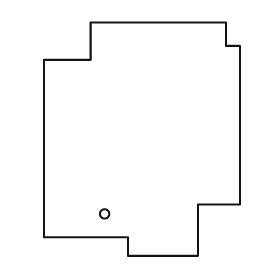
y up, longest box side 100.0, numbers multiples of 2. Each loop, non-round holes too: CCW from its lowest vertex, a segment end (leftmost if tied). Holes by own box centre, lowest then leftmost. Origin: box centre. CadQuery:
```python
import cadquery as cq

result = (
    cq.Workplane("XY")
    .moveTo(-6.0, -50.0)
    .lineTo(24.0, -50.0)
    .lineTo(24.0, -28.0)
    .lineTo(42.0, -28.0)
    .lineTo(42.0, 40.0)
    .lineTo(36.0, 40.0)
    .lineTo(36.0, 50.0)
    .lineTo(-22.0, 50.0)
    .lineTo(-22.0, 34.0)
    .lineTo(-42.0, 34.0)
    .lineTo(-42.0, -42.0)
    .lineTo(-6.0, -42.0)
    .close()
    .moveTo(-16.0, -32.0)
    .circle(2.0)
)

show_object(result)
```